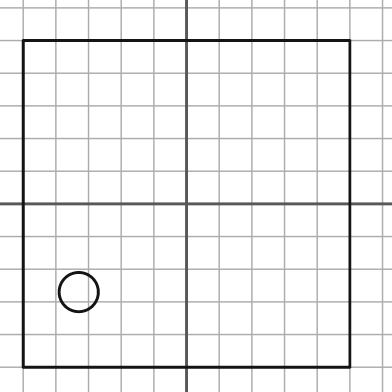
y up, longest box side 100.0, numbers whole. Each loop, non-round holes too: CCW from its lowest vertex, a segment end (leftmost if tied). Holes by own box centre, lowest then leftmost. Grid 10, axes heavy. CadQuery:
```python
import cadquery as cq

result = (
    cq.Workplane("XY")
    .moveTo(-50.0, -50.0)
    .lineTo(50.0, -50.0)
    .lineTo(50.0, 50.0)
    .lineTo(-50.0, 50.0)
    .close()
    .moveTo(-33.0, -27.0)
    .circle(6.0)
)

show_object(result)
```